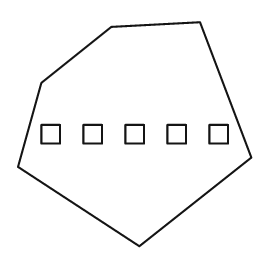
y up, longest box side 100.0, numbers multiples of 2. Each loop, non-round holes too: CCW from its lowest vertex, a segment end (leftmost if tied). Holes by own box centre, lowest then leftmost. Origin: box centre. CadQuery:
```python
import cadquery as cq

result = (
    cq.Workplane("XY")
    .moveTo(2.0, -48.0)
    .lineTo(50.0, -10.0)
    .lineTo(28.0, 48.0)
    .lineTo(-10.0, 46.0)
    .lineTo(-40.0, 22.0)
    .lineTo(-50.0, -14.0)
    .close()
    .moveTo(-40.0, -4.0)
    .lineTo(-32.0, -4.0)
    .lineTo(-32.0, 4.0)
    .lineTo(-40.0, 4.0)
    .close()
    .moveTo(-22.0, -4.0)
    .lineTo(-14.0, -4.0)
    .lineTo(-14.0, 4.0)
    .lineTo(-22.0, 4.0)
    .close()
    .moveTo(-4.0, -4.0)
    .lineTo(4.0, -4.0)
    .lineTo(4.0, 4.0)
    .lineTo(-4.0, 4.0)
    .close()
    .moveTo(14.0, -4.0)
    .lineTo(22.0, -4.0)
    .lineTo(22.0, 4.0)
    .lineTo(14.0, 4.0)
    .close()
    .moveTo(32.0, -4.0)
    .lineTo(40.0, -4.0)
    .lineTo(40.0, 4.0)
    .lineTo(32.0, 4.0)
    .close()
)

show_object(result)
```